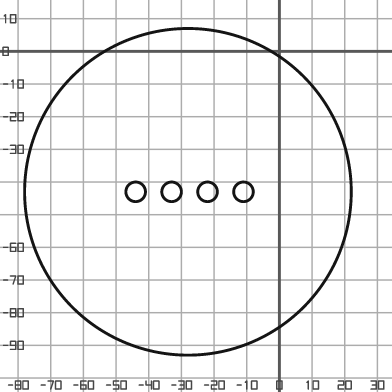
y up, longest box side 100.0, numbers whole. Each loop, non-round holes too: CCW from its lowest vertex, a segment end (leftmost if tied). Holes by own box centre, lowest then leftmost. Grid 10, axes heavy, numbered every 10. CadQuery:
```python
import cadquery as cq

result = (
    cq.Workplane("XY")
    .moveTo(-28.0, -43.0)
    .circle(50.0)
    .moveTo(-44.0, -43.0)
    .circle(3.0)
    .moveTo(-33.0, -43.0)
    .circle(3.0)
    .moveTo(-22.0, -43.0)
    .circle(3.0)
    .moveTo(-11.0, -43.0)
    .circle(3.0)
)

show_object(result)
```